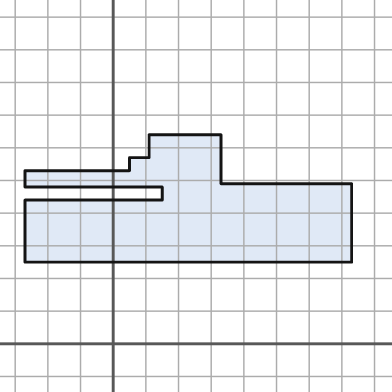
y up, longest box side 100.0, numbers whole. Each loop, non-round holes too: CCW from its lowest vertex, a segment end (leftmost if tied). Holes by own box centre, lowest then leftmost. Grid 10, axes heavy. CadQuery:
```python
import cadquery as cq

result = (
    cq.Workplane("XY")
    .moveTo(-27.0, 25.0)
    .lineTo(73.0, 25.0)
    .lineTo(73.0, 49.0)
    .lineTo(33.0, 49.0)
    .lineTo(33.0, 64.0)
    .lineTo(11.0, 64.0)
    .lineTo(11.0, 57.0)
    .lineTo(5.0, 57.0)
    .lineTo(5.0, 53.0)
    .lineTo(-27.0, 53.0)
    .lineTo(-27.0, 48.0)
    .lineTo(15.0, 48.0)
    .lineTo(15.0, 44.0)
    .lineTo(-27.0, 44.0)
    .close()
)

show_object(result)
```